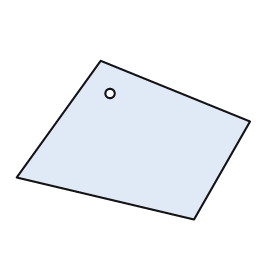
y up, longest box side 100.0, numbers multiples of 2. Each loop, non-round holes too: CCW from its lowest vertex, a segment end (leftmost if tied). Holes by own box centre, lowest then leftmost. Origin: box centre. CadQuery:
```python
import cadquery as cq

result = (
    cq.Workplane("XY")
    .moveTo(26.0, -34.0)
    .lineTo(50.0, 8.0)
    .lineTo(-14.0, 34.0)
    .lineTo(-50.0, -16.0)
    .close()
    .moveTo(-10.0, 20.0)
    .circle(2.0)
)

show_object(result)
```